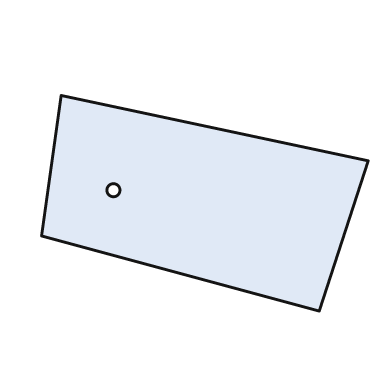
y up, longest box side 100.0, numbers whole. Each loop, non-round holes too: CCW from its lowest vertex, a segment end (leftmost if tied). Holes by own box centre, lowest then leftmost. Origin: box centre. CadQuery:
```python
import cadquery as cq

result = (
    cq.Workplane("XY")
    .moveTo(35.0, -33.0)
    .lineTo(50.0, 13.0)
    .lineTo(-44.0, 33.0)
    .lineTo(-50.0, -10.0)
    .close()
    .moveTo(-28.0, 4.0)
    .circle(2.0)
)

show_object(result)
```